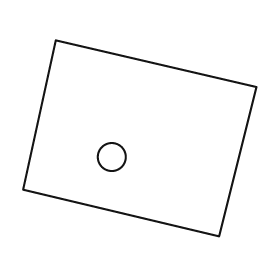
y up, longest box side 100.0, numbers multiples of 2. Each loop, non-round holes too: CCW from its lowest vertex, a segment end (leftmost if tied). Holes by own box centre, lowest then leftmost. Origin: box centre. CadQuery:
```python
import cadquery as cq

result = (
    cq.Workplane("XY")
    .moveTo(34.0, -42.0)
    .lineTo(50.0, 22.0)
    .lineTo(-36.0, 42.0)
    .lineTo(-50.0, -22.0)
    .close()
    .moveTo(-12.0, -8.0)
    .circle(6.0)
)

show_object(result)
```